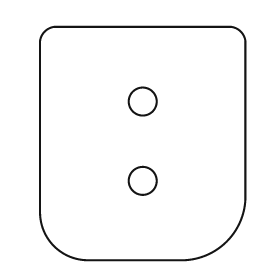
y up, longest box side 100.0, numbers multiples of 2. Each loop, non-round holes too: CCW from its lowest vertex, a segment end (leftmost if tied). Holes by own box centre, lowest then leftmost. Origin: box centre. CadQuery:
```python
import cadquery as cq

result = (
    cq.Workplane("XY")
    .moveTo(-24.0, -50.0)
    .lineTo(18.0, -50.0)
    .threePointArc((36.0, -42.0), (44.0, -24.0))
    .lineTo(44.0, 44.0)
    .threePointArc((42.0, 48.0), (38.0, 50.0))
    .lineTo(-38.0, 50.0)
    .threePointArc((-42.0, 48.0), (-44.0, 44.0))
    .lineTo(-44.0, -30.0)
    .threePointArc((-38.0, -44.0), (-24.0, -50.0))
    .close()
    .moveTo(0.0, -16.0)
    .circle(6.0)
    .moveTo(0.0, 18.0)
    .circle(6.0)
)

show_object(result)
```